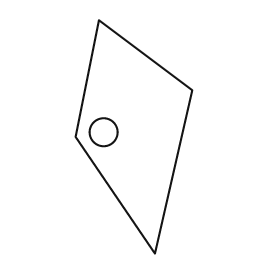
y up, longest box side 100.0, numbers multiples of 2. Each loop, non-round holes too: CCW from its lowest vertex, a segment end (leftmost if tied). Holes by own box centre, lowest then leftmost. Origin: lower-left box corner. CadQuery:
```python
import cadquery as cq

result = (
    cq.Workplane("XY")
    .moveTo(34.0, 0.0)
    .lineTo(50.0, 70.0)
    .lineTo(10.0, 100.0)
    .lineTo(0.0, 50.0)
    .close()
    .moveTo(12.0, 52.0)
    .circle(6.0)
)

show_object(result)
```